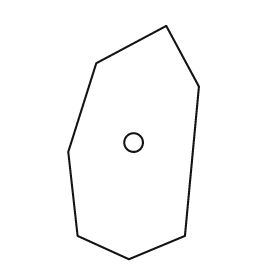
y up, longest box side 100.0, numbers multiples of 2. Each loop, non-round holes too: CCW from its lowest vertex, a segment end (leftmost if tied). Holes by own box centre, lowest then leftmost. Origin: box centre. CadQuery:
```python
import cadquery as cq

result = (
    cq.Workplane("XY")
    .moveTo(-2.0, -50.0)
    .lineTo(22.0, -40.0)
    .lineTo(28.0, 24.0)
    .lineTo(14.0, 50.0)
    .lineTo(-16.0, 34.0)
    .lineTo(-28.0, -4.0)
    .lineTo(-24.0, -40.0)
    .close()
    .moveTo(0.0, 0.0)
    .circle(4.0)
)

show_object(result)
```